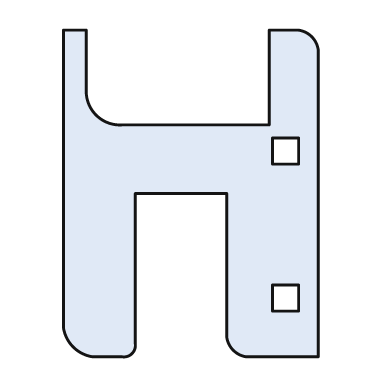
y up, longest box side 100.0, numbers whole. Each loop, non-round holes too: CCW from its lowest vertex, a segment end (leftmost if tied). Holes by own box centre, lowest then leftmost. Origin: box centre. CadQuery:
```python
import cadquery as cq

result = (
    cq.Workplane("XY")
    .moveTo(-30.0, -50.0)
    .lineTo(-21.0, -50.0)
    .threePointArc((-18.0, -49.0), (-17.0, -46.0))
    .lineTo(-17.0, 0.0)
    .lineTo(11.0, 0.0)
    .lineTo(11.0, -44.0)
    .threePointArc((13.0, -48.0), (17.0, -50.0))
    .lineTo(39.0, -50.0)
    .lineTo(39.0, 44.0)
    .threePointArc((37.0, 48.0), (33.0, 50.0))
    .lineTo(24.0, 50.0)
    .lineTo(24.0, 21.0)
    .lineTo(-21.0, 21.0)
    .threePointArc((-29.0, 24.0), (-32.0, 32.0))
    .lineTo(-32.0, 50.0)
    .lineTo(-39.0, 50.0)
    .lineTo(-39.0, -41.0)
    .threePointArc((-36.0, -47.0), (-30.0, -50.0))
    .close()
    .moveTo(25.0, -36.0)
    .lineTo(33.0, -36.0)
    .lineTo(33.0, -28.0)
    .lineTo(25.0, -28.0)
    .close()
    .moveTo(25.0, 9.0)
    .lineTo(33.0, 9.0)
    .lineTo(33.0, 17.0)
    .lineTo(25.0, 17.0)
    .close()
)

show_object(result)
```